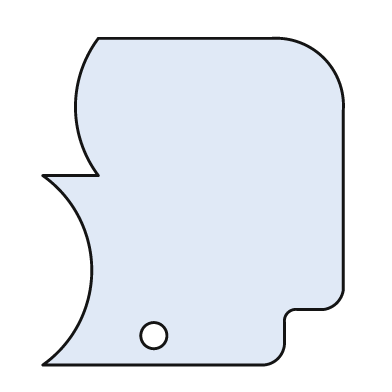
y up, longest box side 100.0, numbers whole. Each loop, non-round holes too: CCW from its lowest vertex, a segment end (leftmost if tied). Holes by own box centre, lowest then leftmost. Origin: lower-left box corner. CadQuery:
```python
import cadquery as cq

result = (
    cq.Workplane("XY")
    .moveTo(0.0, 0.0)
    .lineTo(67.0, 0.0)
    .threePointArc((72.0, 2.0), (74.0, 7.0))
    .lineTo(74.0, 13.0)
    .threePointArc((75.0, 16.0), (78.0, 17.0))
    .lineTo(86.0, 17.0)
    .threePointArc((90.0, 19.0), (92.0, 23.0))
    .lineTo(92.0, 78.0)
    .threePointArc((86.0, 94.0), (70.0, 100.0))
    .lineTo(17.0, 100.0)
    .threePointArc((10.0, 79.0), (17.0, 58.0))
    .lineTo(0.0, 58.0)
    .threePointArc((15.0, 29.0), (0.0, 0.0))
    .close()
    .moveTo(34.0, 9.0)
    .circle(4.0)
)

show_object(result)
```